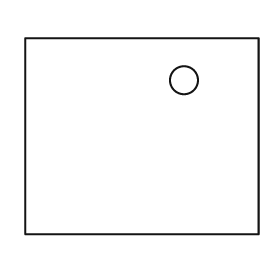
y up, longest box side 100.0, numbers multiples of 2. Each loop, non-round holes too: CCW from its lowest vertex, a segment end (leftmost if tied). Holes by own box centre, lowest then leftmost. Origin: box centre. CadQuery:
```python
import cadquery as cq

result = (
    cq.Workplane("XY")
    .moveTo(-50.0, -42.0)
    .lineTo(50.0, -42.0)
    .lineTo(50.0, 42.0)
    .lineTo(-50.0, 42.0)
    .close()
    .moveTo(18.0, 24.0)
    .circle(6.0)
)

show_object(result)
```